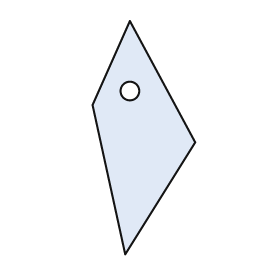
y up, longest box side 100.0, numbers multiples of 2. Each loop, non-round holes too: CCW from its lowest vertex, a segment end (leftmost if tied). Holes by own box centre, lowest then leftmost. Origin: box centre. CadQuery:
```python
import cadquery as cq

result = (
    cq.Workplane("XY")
    .moveTo(-8.0, -50.0)
    .lineTo(22.0, -2.0)
    .lineTo(-6.0, 50.0)
    .lineTo(-22.0, 14.0)
    .close()
    .moveTo(-6.0, 20.0)
    .circle(4.0)
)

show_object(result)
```